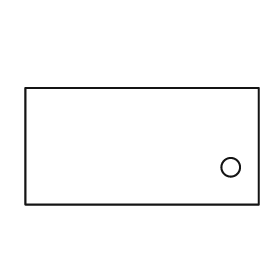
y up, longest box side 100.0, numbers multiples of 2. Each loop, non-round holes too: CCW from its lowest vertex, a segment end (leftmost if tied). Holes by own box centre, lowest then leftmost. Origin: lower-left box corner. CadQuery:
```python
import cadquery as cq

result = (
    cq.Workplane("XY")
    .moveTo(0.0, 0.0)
    .lineTo(100.0, 0.0)
    .lineTo(100.0, 50.0)
    .lineTo(0.0, 50.0)
    .close()
    .moveTo(88.0, 16.0)
    .circle(4.0)
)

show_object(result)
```